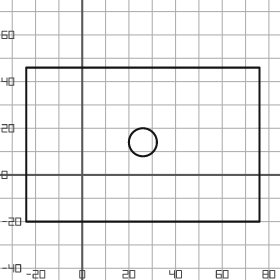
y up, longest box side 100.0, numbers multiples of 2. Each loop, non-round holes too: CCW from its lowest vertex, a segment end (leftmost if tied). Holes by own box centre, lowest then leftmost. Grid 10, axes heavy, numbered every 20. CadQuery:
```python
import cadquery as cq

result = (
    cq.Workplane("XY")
    .moveTo(-24.0, -20.0)
    .lineTo(76.0, -20.0)
    .lineTo(76.0, 46.0)
    .lineTo(-24.0, 46.0)
    .close()
    .moveTo(26.0, 14.0)
    .circle(6.0)
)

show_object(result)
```